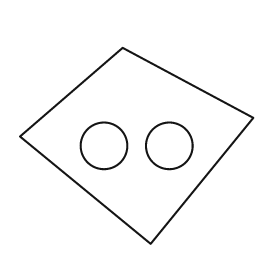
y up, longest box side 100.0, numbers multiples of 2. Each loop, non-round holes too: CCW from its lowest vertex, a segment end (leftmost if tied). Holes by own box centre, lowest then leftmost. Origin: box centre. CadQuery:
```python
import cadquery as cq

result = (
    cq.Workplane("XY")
    .moveTo(6.0, -42.0)
    .lineTo(50.0, 12.0)
    .lineTo(-6.0, 42.0)
    .lineTo(-50.0, 4.0)
    .close()
    .moveTo(-14.0, 0.0)
    .circle(10.0)
    .moveTo(14.0, 0.0)
    .circle(10.0)
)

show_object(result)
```